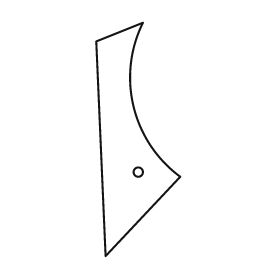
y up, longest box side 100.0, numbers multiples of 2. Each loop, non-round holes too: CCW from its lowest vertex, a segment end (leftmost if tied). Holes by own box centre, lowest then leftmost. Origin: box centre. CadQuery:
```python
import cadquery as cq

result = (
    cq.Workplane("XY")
    .moveTo(-14.0, -50.0)
    .lineTo(18.0, -16.0)
    .threePointArc((-2.0, 14.0), (2.0, 50.0))
    .lineTo(-18.0, 42.0)
    .close()
    .moveTo(0.0, -14.0)
    .circle(2.0)
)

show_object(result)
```